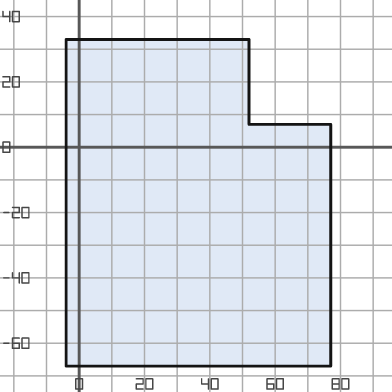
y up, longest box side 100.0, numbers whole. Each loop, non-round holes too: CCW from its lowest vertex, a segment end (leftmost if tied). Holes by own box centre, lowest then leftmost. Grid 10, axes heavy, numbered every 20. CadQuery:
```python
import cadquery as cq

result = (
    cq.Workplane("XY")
    .moveTo(-4.0, -67.0)
    .lineTo(77.0, -67.0)
    .lineTo(77.0, 7.0)
    .lineTo(52.0, 7.0)
    .lineTo(52.0, 33.0)
    .lineTo(-4.0, 33.0)
    .close()
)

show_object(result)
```